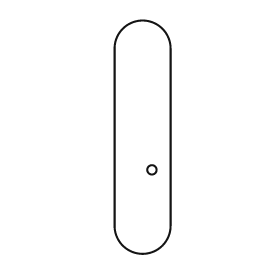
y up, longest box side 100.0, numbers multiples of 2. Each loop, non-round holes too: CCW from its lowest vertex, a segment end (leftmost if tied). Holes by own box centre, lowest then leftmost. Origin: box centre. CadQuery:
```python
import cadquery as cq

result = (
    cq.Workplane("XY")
    .moveTo(-12.0, -38.0)
    .threePointArc((0.0, -50.0), (12.0, -38.0))
    .lineTo(12.0, 38.0)
    .threePointArc((0.0, 50.0), (-12.0, 38.0))
    .close()
    .moveTo(4.0, -14.0)
    .circle(2.0)
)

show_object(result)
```